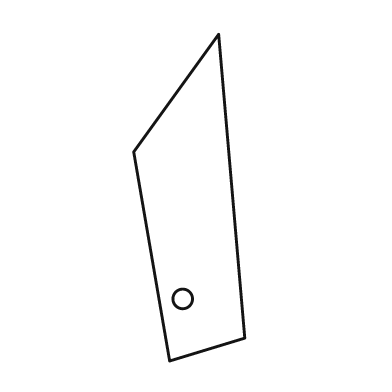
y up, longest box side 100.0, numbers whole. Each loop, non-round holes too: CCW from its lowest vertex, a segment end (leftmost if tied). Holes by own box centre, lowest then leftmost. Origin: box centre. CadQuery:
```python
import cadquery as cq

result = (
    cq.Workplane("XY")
    .moveTo(-6.0, -50.0)
    .lineTo(17.0, -43.0)
    .lineTo(9.0, 50.0)
    .lineTo(-17.0, 14.0)
    .close()
    .moveTo(-2.0, -31.0)
    .circle(3.0)
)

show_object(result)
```